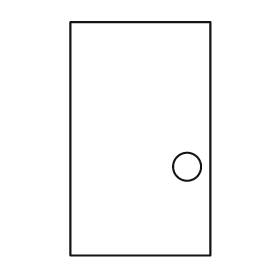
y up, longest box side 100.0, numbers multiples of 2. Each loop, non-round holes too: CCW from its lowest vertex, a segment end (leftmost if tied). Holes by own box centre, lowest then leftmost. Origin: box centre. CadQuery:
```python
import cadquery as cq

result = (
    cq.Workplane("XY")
    .moveTo(-30.0, -50.0)
    .lineTo(30.0, -50.0)
    .lineTo(30.0, 50.0)
    .lineTo(-30.0, 50.0)
    .close()
    .moveTo(20.0, -12.0)
    .circle(6.0)
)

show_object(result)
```